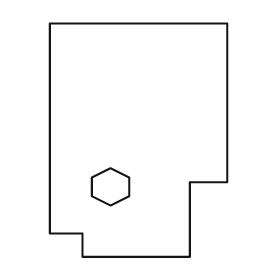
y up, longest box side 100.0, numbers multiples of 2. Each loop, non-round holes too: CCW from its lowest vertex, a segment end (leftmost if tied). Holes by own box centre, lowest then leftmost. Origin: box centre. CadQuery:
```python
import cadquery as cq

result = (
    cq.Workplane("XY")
    .moveTo(-24.0, -50.0)
    .lineTo(22.0, -50.0)
    .lineTo(22.0, -18.0)
    .lineTo(38.0, -18.0)
    .lineTo(38.0, 50.0)
    .lineTo(-38.0, 50.0)
    .lineTo(-38.0, -40.0)
    .lineTo(-24.0, -40.0)
    .close()
    .moveTo(-12.0, -28.0)
    .lineTo(-4.0, -24.0)
    .lineTo(-4.0, -16.0)
    .lineTo(-12.0, -12.0)
    .lineTo(-20.0, -16.0)
    .lineTo(-20.0, -24.0)
    .close()
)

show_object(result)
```